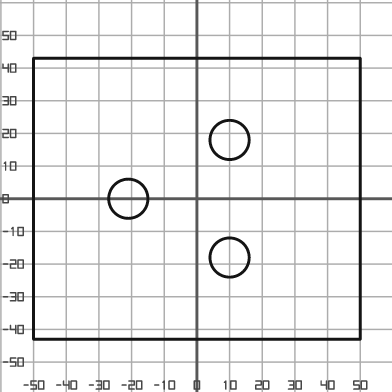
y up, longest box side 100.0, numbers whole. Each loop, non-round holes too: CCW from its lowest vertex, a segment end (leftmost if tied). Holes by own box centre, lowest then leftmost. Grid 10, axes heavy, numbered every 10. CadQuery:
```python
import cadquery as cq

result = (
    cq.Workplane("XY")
    .moveTo(-50.0, -43.0)
    .lineTo(50.0, -43.0)
    .lineTo(50.0, 43.0)
    .lineTo(-50.0, 43.0)
    .close()
    .moveTo(10.0, -18.0)
    .circle(6.0)
    .moveTo(-21.0, 0.0)
    .circle(6.0)
    .moveTo(10.0, 18.0)
    .circle(6.0)
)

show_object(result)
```